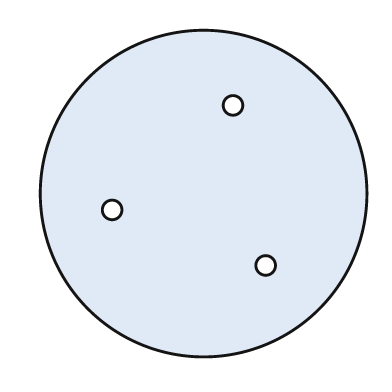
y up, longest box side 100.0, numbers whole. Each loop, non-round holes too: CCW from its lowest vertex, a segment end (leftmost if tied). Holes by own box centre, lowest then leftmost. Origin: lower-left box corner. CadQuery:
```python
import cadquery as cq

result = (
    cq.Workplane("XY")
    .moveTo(50.0, 50.0)
    .circle(50.0)
    .moveTo(69.0, 28.0)
    .circle(3.0)
    .moveTo(22.0, 45.0)
    .circle(3.0)
    .moveTo(59.0, 77.0)
    .circle(3.0)
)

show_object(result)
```